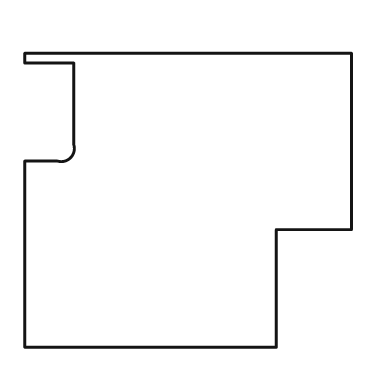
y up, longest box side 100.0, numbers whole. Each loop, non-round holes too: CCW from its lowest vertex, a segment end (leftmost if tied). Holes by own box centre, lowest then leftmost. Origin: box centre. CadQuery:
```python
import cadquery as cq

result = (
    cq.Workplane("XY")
    .moveTo(-50.0, -45.0)
    .lineTo(27.0, -45.0)
    .lineTo(27.0, -9.0)
    .lineTo(50.0, -9.0)
    .lineTo(50.0, 45.0)
    .lineTo(-50.0, 45.0)
    .lineTo(-50.0, 42.0)
    .lineTo(-35.0, 42.0)
    .lineTo(-35.0, 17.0)
    .threePointArc((-36.0, 13.0), (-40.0, 12.0))
    .lineTo(-50.0, 12.0)
    .close()
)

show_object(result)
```